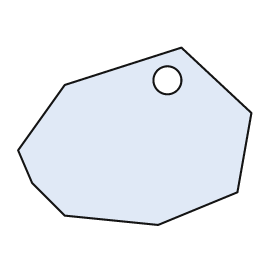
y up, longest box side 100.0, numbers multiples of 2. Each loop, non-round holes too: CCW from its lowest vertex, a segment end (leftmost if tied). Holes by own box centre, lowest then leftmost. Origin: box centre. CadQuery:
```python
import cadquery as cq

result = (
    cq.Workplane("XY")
    .moveTo(10.0, -38.0)
    .lineTo(44.0, -24.0)
    .lineTo(50.0, 10.0)
    .lineTo(20.0, 38.0)
    .lineTo(-30.0, 22.0)
    .lineTo(-50.0, -6.0)
    .lineTo(-44.0, -20.0)
    .lineTo(-30.0, -34.0)
    .close()
    .moveTo(14.0, 24.0)
    .circle(6.0)
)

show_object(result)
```